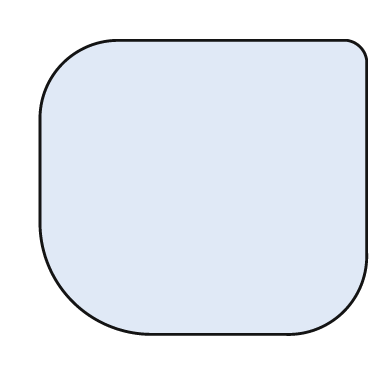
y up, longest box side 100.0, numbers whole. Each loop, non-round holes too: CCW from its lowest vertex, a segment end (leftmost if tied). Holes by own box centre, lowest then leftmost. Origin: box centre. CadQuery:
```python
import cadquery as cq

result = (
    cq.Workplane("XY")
    .moveTo(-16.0, -45.0)
    .lineTo(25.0, -45.0)
    .threePointArc((43.0, -38.0), (50.0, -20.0))
    .lineTo(50.0, 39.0)
    .threePointArc((48.0, 43.0), (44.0, 45.0))
    .lineTo(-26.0, 45.0)
    .threePointArc((-43.0, 38.0), (-50.0, 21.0))
    .lineTo(-50.0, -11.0)
    .threePointArc((-40.0, -35.0), (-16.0, -45.0))
    .close()
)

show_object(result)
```